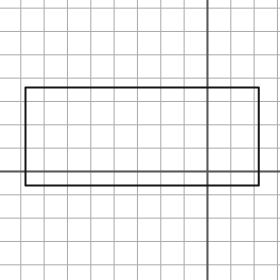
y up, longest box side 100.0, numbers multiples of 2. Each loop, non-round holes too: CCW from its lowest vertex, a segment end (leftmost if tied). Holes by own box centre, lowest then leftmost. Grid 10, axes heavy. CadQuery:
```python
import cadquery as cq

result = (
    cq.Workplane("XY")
    .moveTo(-78.0, -6.0)
    .lineTo(22.0, -6.0)
    .lineTo(22.0, 36.0)
    .lineTo(-78.0, 36.0)
    .close()
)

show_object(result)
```